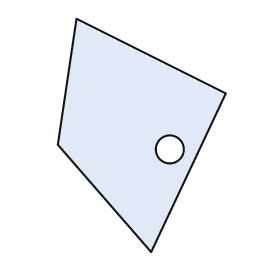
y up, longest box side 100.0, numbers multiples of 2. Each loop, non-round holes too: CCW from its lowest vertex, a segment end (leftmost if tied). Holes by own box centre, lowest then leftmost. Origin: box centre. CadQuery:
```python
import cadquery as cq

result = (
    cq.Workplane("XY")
    .moveTo(4.0, -50.0)
    .lineTo(36.0, 18.0)
    .lineTo(-28.0, 50.0)
    .lineTo(-36.0, -4.0)
    .close()
    .moveTo(12.0, -6.0)
    .circle(6.0)
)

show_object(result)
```